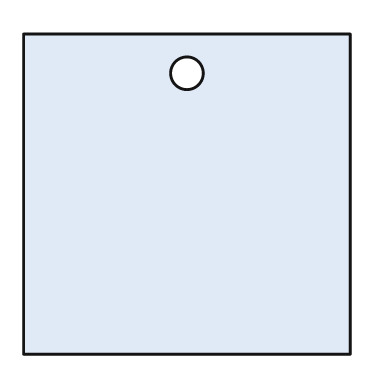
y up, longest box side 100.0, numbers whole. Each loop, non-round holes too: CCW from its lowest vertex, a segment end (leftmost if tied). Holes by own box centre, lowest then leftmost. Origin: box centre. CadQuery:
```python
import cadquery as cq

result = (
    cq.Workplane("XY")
    .moveTo(-50.0, -49.0)
    .lineTo(50.0, -49.0)
    .lineTo(50.0, 49.0)
    .lineTo(-50.0, 49.0)
    .close()
    .moveTo(0.0, 37.0)
    .circle(5.0)
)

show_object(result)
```